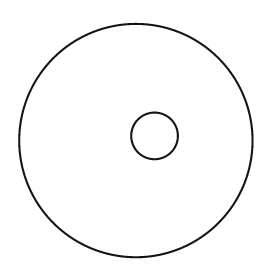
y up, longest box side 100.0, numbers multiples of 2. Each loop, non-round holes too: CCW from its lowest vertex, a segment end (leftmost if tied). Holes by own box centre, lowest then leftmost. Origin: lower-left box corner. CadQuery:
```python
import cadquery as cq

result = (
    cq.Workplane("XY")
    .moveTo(50.0, 50.0)
    .circle(50.0)
    .moveTo(58.0, 52.0)
    .circle(10.0)
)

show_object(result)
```